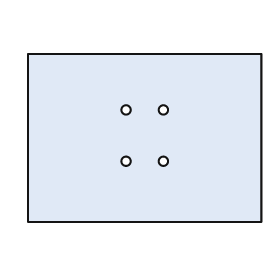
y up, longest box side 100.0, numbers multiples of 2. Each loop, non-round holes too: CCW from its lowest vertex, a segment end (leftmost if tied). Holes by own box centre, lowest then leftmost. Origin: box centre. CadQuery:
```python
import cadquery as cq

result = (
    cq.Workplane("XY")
    .moveTo(-50.0, -36.0)
    .lineTo(50.0, -36.0)
    .lineTo(50.0, 36.0)
    .lineTo(-50.0, 36.0)
    .close()
    .moveTo(-8.0, -10.0)
    .circle(2.0)
    .moveTo(8.0, -10.0)
    .circle(2.0)
    .moveTo(-8.0, 12.0)
    .circle(2.0)
    .moveTo(8.0, 12.0)
    .circle(2.0)
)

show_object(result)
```